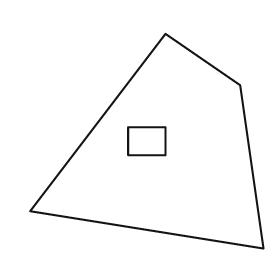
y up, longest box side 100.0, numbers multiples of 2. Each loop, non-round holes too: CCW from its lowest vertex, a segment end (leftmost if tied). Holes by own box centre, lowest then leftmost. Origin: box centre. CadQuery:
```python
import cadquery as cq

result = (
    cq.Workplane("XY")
    .moveTo(50.0, -46.0)
    .lineTo(40.0, 24.0)
    .lineTo(8.0, 46.0)
    .lineTo(-50.0, -30.0)
    .close()
    .moveTo(-8.0, -6.0)
    .lineTo(8.0, -6.0)
    .lineTo(8.0, 6.0)
    .lineTo(-8.0, 6.0)
    .close()
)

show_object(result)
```